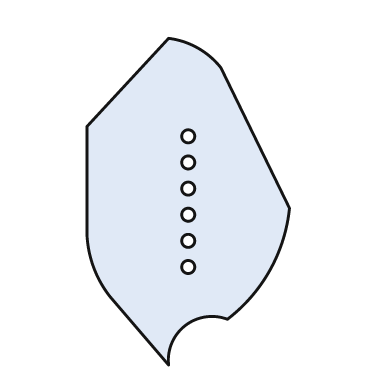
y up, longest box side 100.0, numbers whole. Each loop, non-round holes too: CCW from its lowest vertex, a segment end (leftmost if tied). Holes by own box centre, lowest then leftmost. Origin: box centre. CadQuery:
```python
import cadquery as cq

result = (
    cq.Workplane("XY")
    .moveTo(-6.0, -50.0)
    .threePointArc((-1.0, -38.0), (12.0, -36.0))
    .threePointArc((25.0, -21.0), (31.0, -2.0))
    .lineTo(10.0, 41.0)
    .threePointArc((3.0, 47.0), (-6.0, 50.0))
    .lineTo(-31.0, 23.0)
    .lineTo(-31.0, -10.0)
    .threePointArc((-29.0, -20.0), (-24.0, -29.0))
    .close()
    .moveTo(0.0, -20.0)
    .circle(2.0)
    .moveTo(0.0, -12.0)
    .circle(2.0)
    .moveTo(0.0, -4.0)
    .circle(2.0)
    .moveTo(0.0, 4.0)
    .circle(2.0)
    .moveTo(0.0, 12.0)
    .circle(2.0)
    .moveTo(0.0, 20.0)
    .circle(2.0)
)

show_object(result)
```